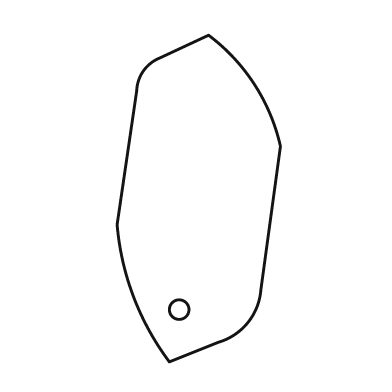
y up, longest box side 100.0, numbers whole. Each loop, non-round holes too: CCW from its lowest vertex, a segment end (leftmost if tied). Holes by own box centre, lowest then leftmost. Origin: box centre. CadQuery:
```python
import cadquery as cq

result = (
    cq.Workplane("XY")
    .moveTo(-9.0, -50.0)
    .lineTo(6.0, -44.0)
    .threePointArc((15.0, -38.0), (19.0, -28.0))
    .lineTo(25.0, 16.0)
    .threePointArc((17.0, 35.0), (3.0, 50.0))
    .lineTo(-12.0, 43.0)
    .threePointArc((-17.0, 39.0), (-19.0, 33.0))
    .lineTo(-25.0, -8.0)
    .threePointArc((-20.0, -30.0), (-9.0, -50.0))
    .close()
    .moveTo(-6.0, -34.0)
    .circle(3.0)
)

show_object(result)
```